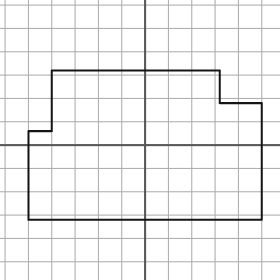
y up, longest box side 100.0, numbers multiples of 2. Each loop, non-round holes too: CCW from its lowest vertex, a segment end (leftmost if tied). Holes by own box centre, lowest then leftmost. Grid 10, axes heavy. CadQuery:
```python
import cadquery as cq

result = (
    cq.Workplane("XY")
    .moveTo(-50.0, -32.0)
    .lineTo(50.0, -32.0)
    .lineTo(50.0, 18.0)
    .lineTo(32.0, 18.0)
    .lineTo(32.0, 32.0)
    .lineTo(-40.0, 32.0)
    .lineTo(-40.0, 6.0)
    .lineTo(-50.0, 6.0)
    .close()
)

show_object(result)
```